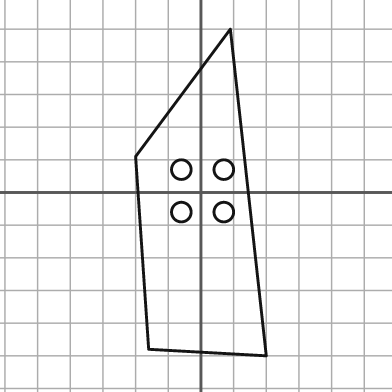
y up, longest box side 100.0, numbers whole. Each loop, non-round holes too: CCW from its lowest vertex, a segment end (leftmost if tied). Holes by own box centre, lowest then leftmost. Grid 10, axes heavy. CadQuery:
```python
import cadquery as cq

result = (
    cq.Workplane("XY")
    .moveTo(20.0, -50.0)
    .lineTo(9.0, 50.0)
    .lineTo(-20.0, 11.0)
    .lineTo(-16.0, -48.0)
    .close()
    .moveTo(-6.0, -6.0)
    .circle(3.0)
    .moveTo(7.0, -6.0)
    .circle(3.0)
    .moveTo(-6.0, 7.0)
    .circle(3.0)
    .moveTo(7.0, 7.0)
    .circle(3.0)
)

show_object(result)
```